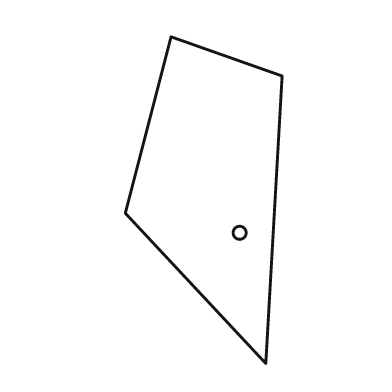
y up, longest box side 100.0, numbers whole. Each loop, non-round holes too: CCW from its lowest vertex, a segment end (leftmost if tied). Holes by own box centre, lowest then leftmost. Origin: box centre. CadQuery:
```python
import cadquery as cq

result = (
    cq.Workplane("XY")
    .moveTo(19.0, -50.0)
    .lineTo(24.0, 38.0)
    .lineTo(-10.0, 50.0)
    .lineTo(-24.0, -4.0)
    .close()
    .moveTo(11.0, -10.0)
    .circle(2.0)
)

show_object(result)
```